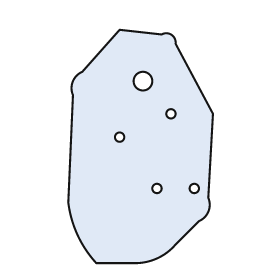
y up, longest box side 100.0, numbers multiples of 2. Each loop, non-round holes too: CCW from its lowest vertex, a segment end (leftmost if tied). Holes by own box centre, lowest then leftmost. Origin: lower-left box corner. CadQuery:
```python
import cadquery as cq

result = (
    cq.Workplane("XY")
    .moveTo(12.0, 0.0)
    .lineTo(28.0, 0.0)
    .threePointArc((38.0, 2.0), (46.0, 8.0))
    .lineTo(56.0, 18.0)
    .threePointArc((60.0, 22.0), (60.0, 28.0))
    .lineTo(62.0, 64.0)
    .lineTo(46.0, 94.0)
    .threePointArc((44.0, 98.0), (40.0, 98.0))
    .lineTo(22.0, 100.0)
    .lineTo(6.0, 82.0)
    .threePointArc((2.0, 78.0), (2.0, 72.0))
    .lineTo(0.0, 26.0)
    .threePointArc((4.0, 12.0), (12.0, 0.0))
    .close()
    .moveTo(38.0, 32.0)
    .circle(2.0)
    .moveTo(54.0, 32.0)
    .circle(2.0)
    .moveTo(22.0, 54.0)
    .circle(2.0)
    .moveTo(44.0, 64.0)
    .circle(2.0)
    .moveTo(32.0, 78.0)
    .circle(4.0)
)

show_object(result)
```